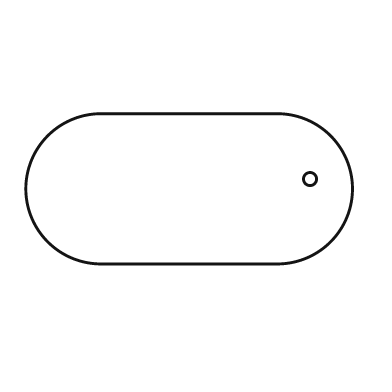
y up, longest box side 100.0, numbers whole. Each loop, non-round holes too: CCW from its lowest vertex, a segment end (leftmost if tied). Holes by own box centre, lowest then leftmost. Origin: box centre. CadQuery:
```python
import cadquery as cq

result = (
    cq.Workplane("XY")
    .moveTo(-27.0, -23.0)
    .lineTo(27.0, -23.0)
    .threePointArc((50.0, 0.0), (27.0, 23.0))
    .lineTo(-27.0, 23.0)
    .threePointArc((-50.0, 0.0), (-27.0, -23.0))
    .close()
    .moveTo(37.0, 3.0)
    .circle(2.0)
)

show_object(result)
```